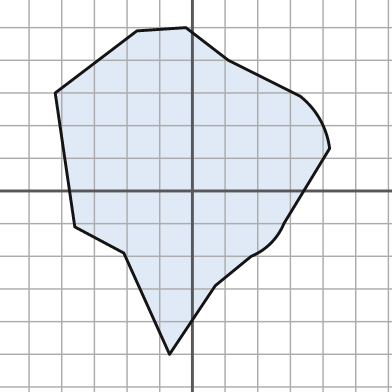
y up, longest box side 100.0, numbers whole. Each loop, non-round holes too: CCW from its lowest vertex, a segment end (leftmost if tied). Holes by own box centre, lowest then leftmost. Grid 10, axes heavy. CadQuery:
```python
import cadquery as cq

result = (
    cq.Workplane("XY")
    .moveTo(-7.0, -50.0)
    .lineTo(7.0, -29.0)
    .lineTo(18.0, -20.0)
    .threePointArc((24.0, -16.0), (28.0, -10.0))
    .lineTo(42.0, 13.0)
    .threePointArc((39.0, 22.0), (33.0, 29.0))
    .lineTo(11.0, 40.0)
    .lineTo(-2.0, 50.0)
    .lineTo(-17.0, 49.0)
    .lineTo(-42.0, 30.0)
    .lineTo(-36.0, -11.0)
    .lineTo(-21.0, -19.0)
    .close()
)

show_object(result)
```